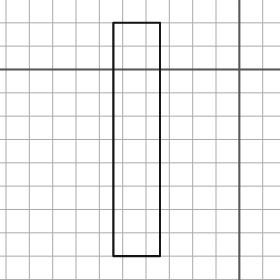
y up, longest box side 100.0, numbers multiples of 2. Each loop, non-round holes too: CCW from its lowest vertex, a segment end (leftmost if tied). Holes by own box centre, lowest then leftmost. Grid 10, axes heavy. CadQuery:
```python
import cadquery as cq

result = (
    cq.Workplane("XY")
    .moveTo(-54.0, -80.0)
    .lineTo(-34.0, -80.0)
    .lineTo(-34.0, 20.0)
    .lineTo(-54.0, 20.0)
    .close()
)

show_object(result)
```